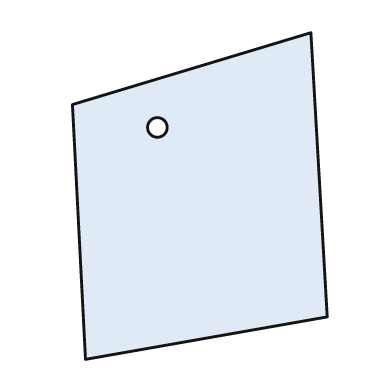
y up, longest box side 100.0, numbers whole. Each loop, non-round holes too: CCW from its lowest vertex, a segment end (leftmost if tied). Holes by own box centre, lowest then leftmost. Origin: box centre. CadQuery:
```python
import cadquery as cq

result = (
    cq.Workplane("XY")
    .moveTo(-35.0, -50.0)
    .lineTo(39.0, -37.0)
    .lineTo(34.0, 50.0)
    .lineTo(-39.0, 28.0)
    .close()
    .moveTo(-13.0, 21.0)
    .circle(3.0)
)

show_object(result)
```